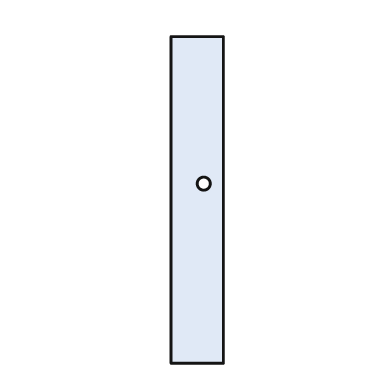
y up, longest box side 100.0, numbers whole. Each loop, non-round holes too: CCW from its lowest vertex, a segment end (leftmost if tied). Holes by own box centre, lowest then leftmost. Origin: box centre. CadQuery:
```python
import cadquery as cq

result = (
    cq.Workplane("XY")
    .moveTo(-8.0, -50.0)
    .lineTo(8.0, -50.0)
    .lineTo(8.0, 50.0)
    .lineTo(-8.0, 50.0)
    .close()
    .moveTo(2.0, 5.0)
    .circle(2.0)
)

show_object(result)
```